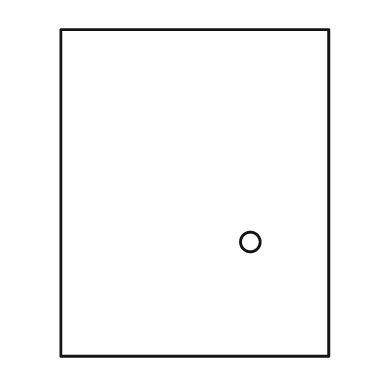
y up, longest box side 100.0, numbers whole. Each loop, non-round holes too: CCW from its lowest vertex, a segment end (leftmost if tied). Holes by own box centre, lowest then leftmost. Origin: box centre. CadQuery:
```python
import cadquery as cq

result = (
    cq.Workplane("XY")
    .moveTo(-41.0, -50.0)
    .lineTo(41.0, -50.0)
    .lineTo(41.0, 50.0)
    .lineTo(-41.0, 50.0)
    .close()
    .moveTo(17.0, -15.0)
    .circle(3.0)
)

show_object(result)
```